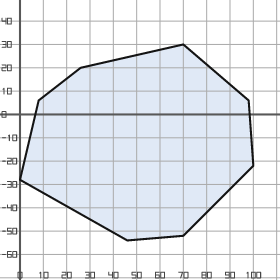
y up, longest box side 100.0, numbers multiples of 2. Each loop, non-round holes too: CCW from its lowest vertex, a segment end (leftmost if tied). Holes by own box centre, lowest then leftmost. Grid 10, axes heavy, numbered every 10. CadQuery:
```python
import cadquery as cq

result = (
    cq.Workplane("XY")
    .moveTo(46.0, -54.0)
    .lineTo(70.0, -52.0)
    .lineTo(100.0, -22.0)
    .lineTo(98.0, 6.0)
    .lineTo(70.0, 30.0)
    .lineTo(26.0, 20.0)
    .lineTo(8.0, 6.0)
    .lineTo(0.0, -28.0)
    .close()
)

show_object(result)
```